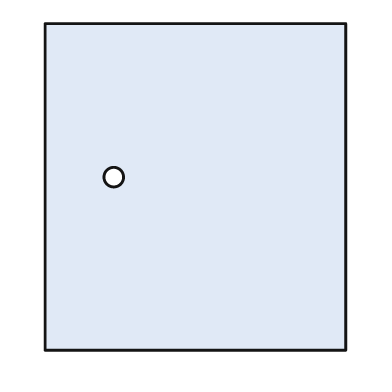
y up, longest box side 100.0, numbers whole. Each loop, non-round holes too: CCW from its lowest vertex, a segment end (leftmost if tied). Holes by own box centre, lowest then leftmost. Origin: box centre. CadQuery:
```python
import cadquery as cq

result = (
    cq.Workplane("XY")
    .moveTo(-46.0, -50.0)
    .lineTo(46.0, -50.0)
    .lineTo(46.0, 50.0)
    .lineTo(-46.0, 50.0)
    .close()
    .moveTo(-25.0, 3.0)
    .circle(3.0)
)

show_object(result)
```